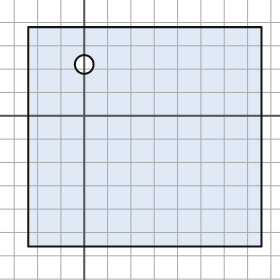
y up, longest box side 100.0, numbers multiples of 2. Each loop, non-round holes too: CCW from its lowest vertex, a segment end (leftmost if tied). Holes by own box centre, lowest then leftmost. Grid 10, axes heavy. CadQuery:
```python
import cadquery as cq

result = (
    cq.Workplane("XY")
    .moveTo(-24.0, -56.0)
    .lineTo(76.0, -56.0)
    .lineTo(76.0, 38.0)
    .lineTo(-24.0, 38.0)
    .close()
    .moveTo(0.0, 22.0)
    .circle(4.0)
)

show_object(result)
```